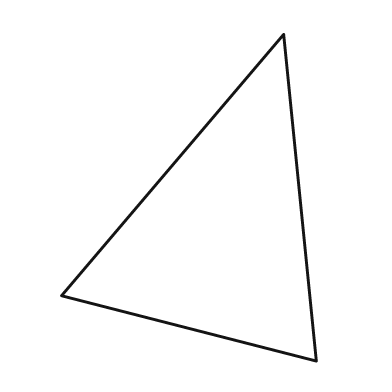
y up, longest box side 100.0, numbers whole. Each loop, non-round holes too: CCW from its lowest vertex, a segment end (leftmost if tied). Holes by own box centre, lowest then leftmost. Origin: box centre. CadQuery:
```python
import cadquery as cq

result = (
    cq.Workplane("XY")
    .moveTo(39.0, -50.0)
    .lineTo(29.0, 50.0)
    .lineTo(-39.0, -30.0)
    .close()
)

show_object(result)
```